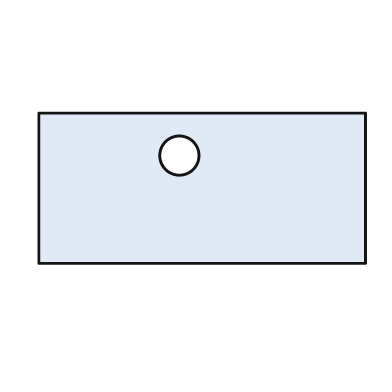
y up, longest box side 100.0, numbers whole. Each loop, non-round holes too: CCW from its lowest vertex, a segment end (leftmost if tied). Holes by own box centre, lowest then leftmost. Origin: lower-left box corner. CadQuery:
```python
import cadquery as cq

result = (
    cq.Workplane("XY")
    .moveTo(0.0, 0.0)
    .lineTo(100.0, 0.0)
    .lineTo(100.0, 46.0)
    .lineTo(0.0, 46.0)
    .close()
    .moveTo(43.0, 33.0)
    .circle(6.0)
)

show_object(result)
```